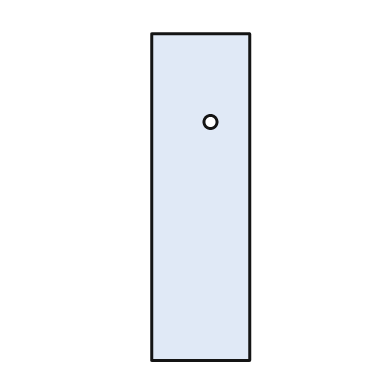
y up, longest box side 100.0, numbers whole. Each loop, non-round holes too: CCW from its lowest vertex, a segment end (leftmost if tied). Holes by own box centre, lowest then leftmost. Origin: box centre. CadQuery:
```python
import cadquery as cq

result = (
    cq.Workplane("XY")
    .moveTo(-15.0, -50.0)
    .lineTo(15.0, -50.0)
    .lineTo(15.0, 50.0)
    .lineTo(-15.0, 50.0)
    .close()
    .moveTo(3.0, 23.0)
    .circle(2.0)
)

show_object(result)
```